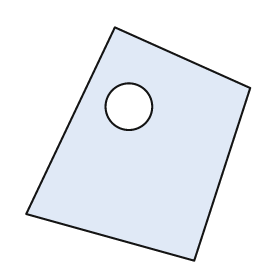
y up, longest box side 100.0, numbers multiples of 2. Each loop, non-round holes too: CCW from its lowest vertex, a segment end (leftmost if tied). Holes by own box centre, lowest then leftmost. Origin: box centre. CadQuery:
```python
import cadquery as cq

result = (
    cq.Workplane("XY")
    .moveTo(24.0, -50.0)
    .lineTo(48.0, 24.0)
    .lineTo(-10.0, 50.0)
    .lineTo(-48.0, -30.0)
    .close()
    .moveTo(-4.0, 16.0)
    .circle(10.0)
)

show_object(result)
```